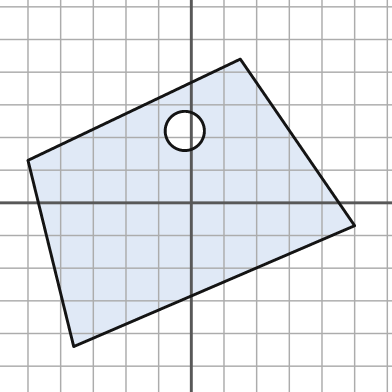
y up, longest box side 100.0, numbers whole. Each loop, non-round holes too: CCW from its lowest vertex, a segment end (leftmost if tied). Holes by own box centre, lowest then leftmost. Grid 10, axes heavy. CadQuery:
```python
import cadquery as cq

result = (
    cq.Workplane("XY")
    .moveTo(-36.0, -44.0)
    .lineTo(50.0, -7.0)
    .lineTo(15.0, 44.0)
    .lineTo(-50.0, 13.0)
    .close()
    .moveTo(-2.0, 22.0)
    .circle(6.0)
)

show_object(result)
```